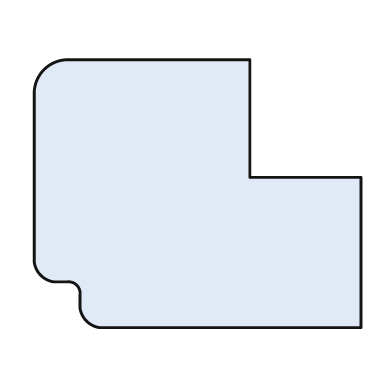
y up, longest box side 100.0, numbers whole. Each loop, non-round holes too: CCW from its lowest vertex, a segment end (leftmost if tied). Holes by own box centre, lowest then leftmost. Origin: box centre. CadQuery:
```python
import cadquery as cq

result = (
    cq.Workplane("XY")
    .moveTo(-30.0, -41.0)
    .lineTo(50.0, -41.0)
    .lineTo(50.0, 5.0)
    .lineTo(16.0, 5.0)
    .lineTo(16.0, 41.0)
    .lineTo(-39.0, 41.0)
    .threePointArc((-47.0, 38.0), (-50.0, 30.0))
    .lineTo(-50.0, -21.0)
    .threePointArc((-48.0, -25.0), (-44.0, -27.0))
    .lineTo(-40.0, -27.0)
    .threePointArc((-37.0, -28.0), (-36.0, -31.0))
    .lineTo(-36.0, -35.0)
    .threePointArc((-34.0, -39.0), (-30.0, -41.0))
    .close()
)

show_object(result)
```